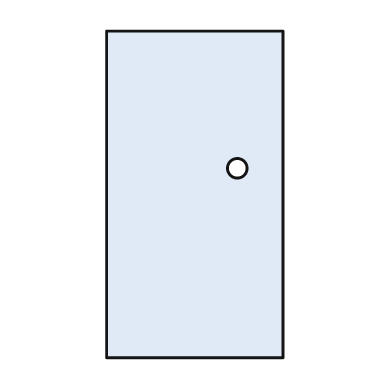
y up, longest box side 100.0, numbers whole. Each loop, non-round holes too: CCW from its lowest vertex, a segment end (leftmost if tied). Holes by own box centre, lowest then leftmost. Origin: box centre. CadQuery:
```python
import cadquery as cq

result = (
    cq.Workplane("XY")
    .moveTo(-27.0, -50.0)
    .lineTo(27.0, -50.0)
    .lineTo(27.0, 50.0)
    .lineTo(-27.0, 50.0)
    .close()
    .moveTo(13.0, 8.0)
    .circle(3.0)
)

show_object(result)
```